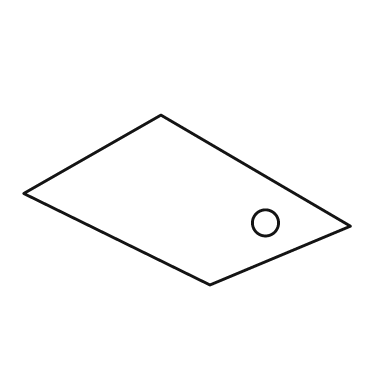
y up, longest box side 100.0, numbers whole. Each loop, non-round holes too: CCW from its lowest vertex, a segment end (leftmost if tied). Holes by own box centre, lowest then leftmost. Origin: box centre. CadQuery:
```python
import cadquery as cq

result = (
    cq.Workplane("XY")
    .moveTo(7.0, -26.0)
    .lineTo(50.0, -8.0)
    .lineTo(-8.0, 26.0)
    .lineTo(-50.0, 2.0)
    .close()
    .moveTo(24.0, -7.0)
    .circle(4.0)
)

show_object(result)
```